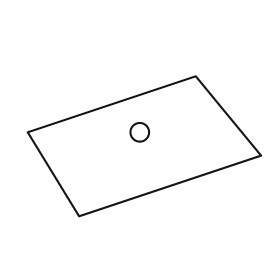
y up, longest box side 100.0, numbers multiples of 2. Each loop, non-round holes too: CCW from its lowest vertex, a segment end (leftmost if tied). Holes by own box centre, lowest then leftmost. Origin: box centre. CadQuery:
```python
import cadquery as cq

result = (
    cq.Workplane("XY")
    .moveTo(-28.0, -30.0)
    .lineTo(50.0, -4.0)
    .lineTo(22.0, 30.0)
    .lineTo(-50.0, 6.0)
    .close()
    .moveTo(-2.0, 6.0)
    .circle(4.0)
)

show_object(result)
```